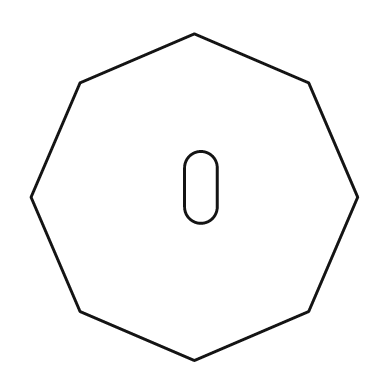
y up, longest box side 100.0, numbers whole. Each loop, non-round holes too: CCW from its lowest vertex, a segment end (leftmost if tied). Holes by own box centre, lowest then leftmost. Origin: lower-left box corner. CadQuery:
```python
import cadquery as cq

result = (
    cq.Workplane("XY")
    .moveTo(50.0, 0.0)
    .lineTo(85.0, 15.0)
    .lineTo(100.0, 50.0)
    .lineTo(85.0, 85.0)
    .lineTo(50.0, 100.0)
    .lineTo(15.0, 85.0)
    .lineTo(0.0, 50.0)
    .lineTo(15.0, 15.0)
    .close()
    .moveTo(47.0, 47.0)
    .threePointArc((52.0, 42.0), (57.0, 47.0))
    .lineTo(57.0, 59.0)
    .threePointArc((52.0, 64.0), (47.0, 59.0))
    .close()
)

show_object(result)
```